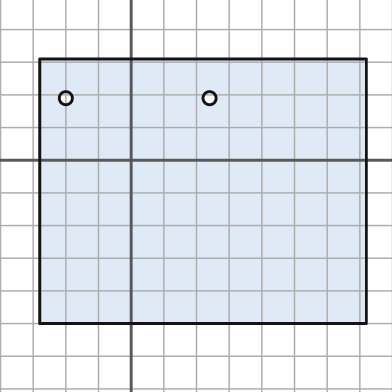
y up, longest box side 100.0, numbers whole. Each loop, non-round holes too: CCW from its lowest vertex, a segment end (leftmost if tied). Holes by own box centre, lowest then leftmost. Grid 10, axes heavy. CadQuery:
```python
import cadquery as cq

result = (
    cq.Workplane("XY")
    .moveTo(-28.0, -50.0)
    .lineTo(72.0, -50.0)
    .lineTo(72.0, 31.0)
    .lineTo(-28.0, 31.0)
    .close()
    .moveTo(-20.0, 19.0)
    .circle(2.0)
    .moveTo(24.0, 19.0)
    .circle(2.0)
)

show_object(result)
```